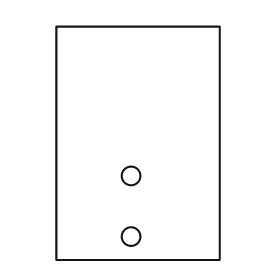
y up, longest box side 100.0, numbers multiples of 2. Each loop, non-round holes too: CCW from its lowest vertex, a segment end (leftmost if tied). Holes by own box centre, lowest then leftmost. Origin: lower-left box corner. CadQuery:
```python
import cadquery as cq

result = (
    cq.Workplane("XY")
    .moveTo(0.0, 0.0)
    .lineTo(70.0, 0.0)
    .lineTo(70.0, 100.0)
    .lineTo(0.0, 100.0)
    .close()
    .moveTo(32.0, 10.0)
    .circle(4.0)
    .moveTo(32.0, 36.0)
    .circle(4.0)
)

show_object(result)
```